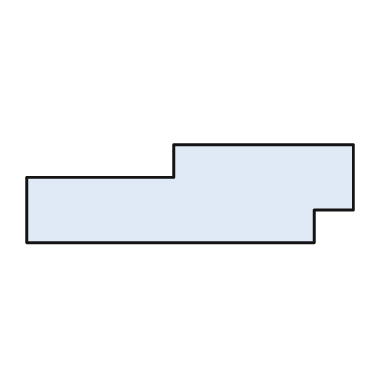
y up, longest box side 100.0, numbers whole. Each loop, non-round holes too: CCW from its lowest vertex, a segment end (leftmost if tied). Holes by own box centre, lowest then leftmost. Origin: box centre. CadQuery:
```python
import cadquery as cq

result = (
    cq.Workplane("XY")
    .moveTo(-50.0, -15.0)
    .lineTo(38.0, -15.0)
    .lineTo(38.0, -5.0)
    .lineTo(50.0, -5.0)
    .lineTo(50.0, 15.0)
    .lineTo(-5.0, 15.0)
    .lineTo(-5.0, 5.0)
    .lineTo(-50.0, 5.0)
    .close()
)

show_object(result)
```